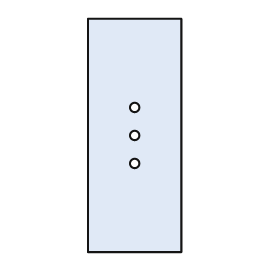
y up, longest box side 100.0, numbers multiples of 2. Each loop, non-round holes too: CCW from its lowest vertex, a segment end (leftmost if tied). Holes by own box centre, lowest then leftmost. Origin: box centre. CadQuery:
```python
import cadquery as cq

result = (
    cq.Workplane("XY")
    .moveTo(-20.0, -50.0)
    .lineTo(20.0, -50.0)
    .lineTo(20.0, 50.0)
    .lineTo(-20.0, 50.0)
    .close()
    .moveTo(0.0, -12.0)
    .circle(2.0)
    .moveTo(0.0, 0.0)
    .circle(2.0)
    .moveTo(0.0, 12.0)
    .circle(2.0)
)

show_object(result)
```